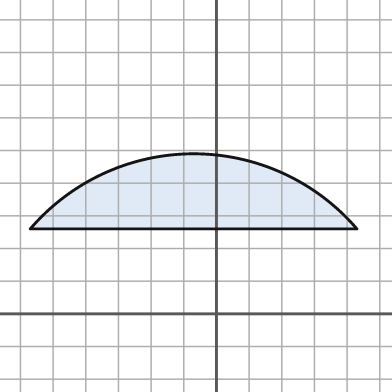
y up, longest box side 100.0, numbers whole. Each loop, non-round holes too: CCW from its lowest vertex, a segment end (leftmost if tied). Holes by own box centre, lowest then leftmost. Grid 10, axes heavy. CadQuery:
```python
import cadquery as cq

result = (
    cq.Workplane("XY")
    .moveTo(-57.0, 26.0)
    .lineTo(43.0, 26.0)
    .threePointArc((-7.0, 49.0), (-57.0, 26.0))
    .close()
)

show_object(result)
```